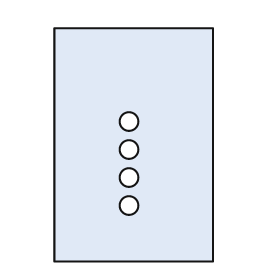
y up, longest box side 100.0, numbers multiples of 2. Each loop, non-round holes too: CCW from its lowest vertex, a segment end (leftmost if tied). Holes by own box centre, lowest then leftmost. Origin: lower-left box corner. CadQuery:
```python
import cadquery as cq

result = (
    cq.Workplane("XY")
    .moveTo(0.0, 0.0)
    .lineTo(68.0, 0.0)
    .lineTo(68.0, 100.0)
    .lineTo(0.0, 100.0)
    .close()
    .moveTo(32.0, 24.0)
    .circle(4.0)
    .moveTo(32.0, 36.0)
    .circle(4.0)
    .moveTo(32.0, 48.0)
    .circle(4.0)
    .moveTo(32.0, 60.0)
    .circle(4.0)
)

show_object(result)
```